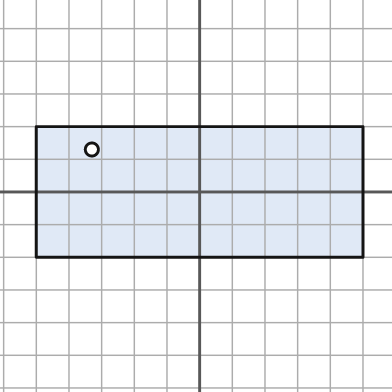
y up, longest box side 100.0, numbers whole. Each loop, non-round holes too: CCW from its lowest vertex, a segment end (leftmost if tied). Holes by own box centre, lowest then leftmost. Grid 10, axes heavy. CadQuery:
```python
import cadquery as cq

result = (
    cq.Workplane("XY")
    .moveTo(-50.0, -20.0)
    .lineTo(50.0, -20.0)
    .lineTo(50.0, 20.0)
    .lineTo(-50.0, 20.0)
    .close()
    .moveTo(-33.0, 13.0)
    .circle(2.0)
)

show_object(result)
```